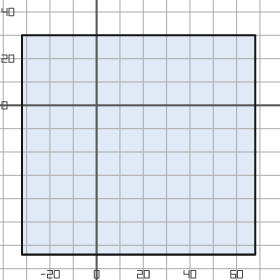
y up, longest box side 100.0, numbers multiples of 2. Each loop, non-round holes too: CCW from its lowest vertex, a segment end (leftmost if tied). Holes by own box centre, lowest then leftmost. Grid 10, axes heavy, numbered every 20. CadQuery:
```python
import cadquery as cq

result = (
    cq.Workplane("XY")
    .moveTo(-32.0, -64.0)
    .lineTo(68.0, -64.0)
    .lineTo(68.0, 30.0)
    .lineTo(-32.0, 30.0)
    .close()
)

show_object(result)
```